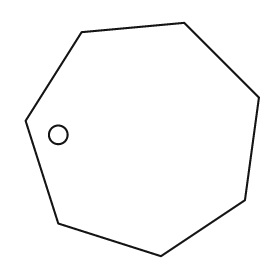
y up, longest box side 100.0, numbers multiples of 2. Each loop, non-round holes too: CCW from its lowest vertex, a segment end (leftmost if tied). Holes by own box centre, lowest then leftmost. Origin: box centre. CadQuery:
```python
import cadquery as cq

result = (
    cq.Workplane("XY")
    .moveTo(8.0, -50.0)
    .lineTo(44.0, -26.0)
    .lineTo(50.0, 18.0)
    .lineTo(18.0, 50.0)
    .lineTo(-26.0, 46.0)
    .lineTo(-50.0, 8.0)
    .lineTo(-36.0, -36.0)
    .close()
    .moveTo(-36.0, 2.0)
    .circle(4.0)
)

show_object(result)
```